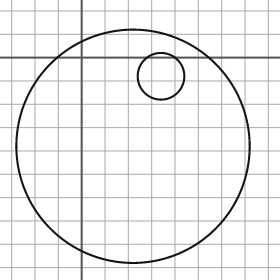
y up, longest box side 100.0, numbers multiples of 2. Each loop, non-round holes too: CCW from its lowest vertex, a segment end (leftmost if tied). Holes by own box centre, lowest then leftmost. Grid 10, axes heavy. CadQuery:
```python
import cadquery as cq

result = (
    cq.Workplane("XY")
    .moveTo(22.0, -38.0)
    .circle(50.0)
    .moveTo(34.0, -8.0)
    .circle(10.0)
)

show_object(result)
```